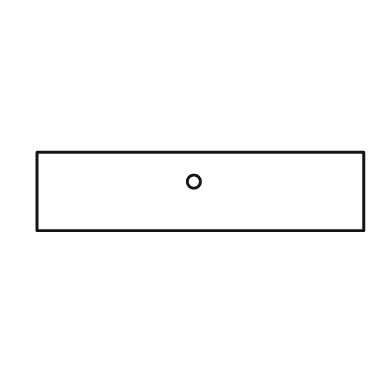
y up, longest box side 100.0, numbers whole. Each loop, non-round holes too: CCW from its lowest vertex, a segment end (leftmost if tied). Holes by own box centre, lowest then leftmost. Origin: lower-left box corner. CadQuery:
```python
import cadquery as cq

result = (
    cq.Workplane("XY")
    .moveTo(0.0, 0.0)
    .lineTo(100.0, 0.0)
    .lineTo(100.0, 24.0)
    .lineTo(0.0, 24.0)
    .close()
    .moveTo(48.0, 15.0)
    .circle(2.0)
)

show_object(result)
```